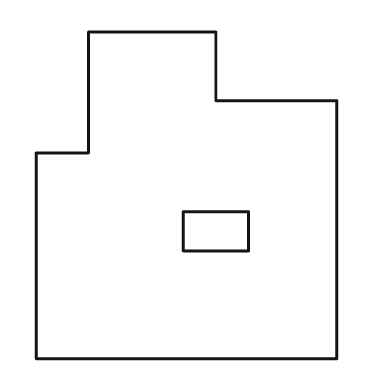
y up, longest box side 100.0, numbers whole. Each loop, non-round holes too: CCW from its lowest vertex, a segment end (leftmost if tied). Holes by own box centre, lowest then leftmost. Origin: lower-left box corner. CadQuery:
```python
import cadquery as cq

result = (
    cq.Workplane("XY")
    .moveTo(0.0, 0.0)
    .lineTo(92.0, 0.0)
    .lineTo(92.0, 79.0)
    .lineTo(55.0, 79.0)
    .lineTo(55.0, 100.0)
    .lineTo(16.0, 100.0)
    .lineTo(16.0, 63.0)
    .lineTo(0.0, 63.0)
    .close()
    .moveTo(45.0, 33.0)
    .lineTo(65.0, 33.0)
    .lineTo(65.0, 45.0)
    .lineTo(45.0, 45.0)
    .close()
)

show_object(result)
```